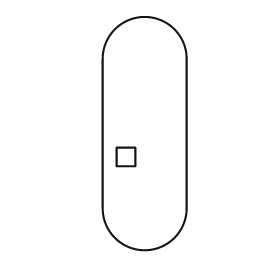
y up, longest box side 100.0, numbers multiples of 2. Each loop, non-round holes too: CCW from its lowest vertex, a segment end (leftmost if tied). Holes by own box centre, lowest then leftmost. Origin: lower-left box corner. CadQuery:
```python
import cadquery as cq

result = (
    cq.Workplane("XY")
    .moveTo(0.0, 18.0)
    .threePointArc((18.0, 0.0), (36.0, 18.0))
    .lineTo(36.0, 82.0)
    .threePointArc((18.0, 100.0), (0.0, 82.0))
    .close()
    .moveTo(6.0, 36.0)
    .lineTo(14.0, 36.0)
    .lineTo(14.0, 44.0)
    .lineTo(6.0, 44.0)
    .close()
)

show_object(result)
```